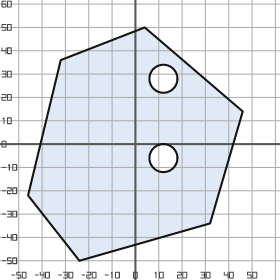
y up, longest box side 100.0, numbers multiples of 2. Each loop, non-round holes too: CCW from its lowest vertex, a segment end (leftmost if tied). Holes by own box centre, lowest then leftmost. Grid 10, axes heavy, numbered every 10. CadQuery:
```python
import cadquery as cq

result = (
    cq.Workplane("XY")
    .moveTo(-24.0, -50.0)
    .lineTo(32.0, -34.0)
    .lineTo(46.0, 14.0)
    .lineTo(4.0, 50.0)
    .lineTo(-32.0, 36.0)
    .lineTo(-46.0, -22.0)
    .close()
    .moveTo(12.0, -6.0)
    .circle(6.0)
    .moveTo(12.0, 28.0)
    .circle(6.0)
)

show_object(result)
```